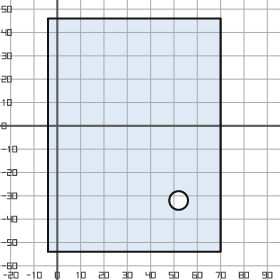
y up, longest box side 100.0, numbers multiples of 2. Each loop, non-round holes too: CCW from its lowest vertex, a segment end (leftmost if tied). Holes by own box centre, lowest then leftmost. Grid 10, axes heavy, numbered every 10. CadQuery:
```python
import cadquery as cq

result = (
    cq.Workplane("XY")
    .moveTo(-4.0, -54.0)
    .lineTo(70.0, -54.0)
    .lineTo(70.0, 46.0)
    .lineTo(-4.0, 46.0)
    .close()
    .moveTo(52.0, -32.0)
    .circle(4.0)
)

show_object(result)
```